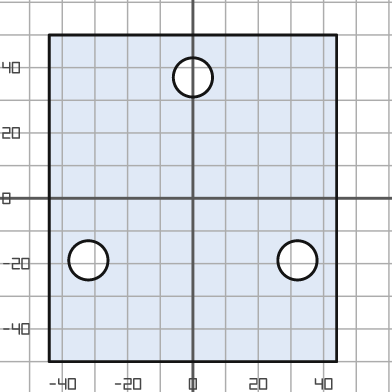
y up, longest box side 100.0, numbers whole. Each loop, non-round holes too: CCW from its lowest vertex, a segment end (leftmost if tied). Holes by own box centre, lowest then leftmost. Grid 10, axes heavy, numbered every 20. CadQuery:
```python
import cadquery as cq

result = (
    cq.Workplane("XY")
    .moveTo(-44.0, -50.0)
    .lineTo(44.0, -50.0)
    .lineTo(44.0, 50.0)
    .lineTo(-44.0, 50.0)
    .close()
    .moveTo(-32.0, -19.0)
    .circle(6.0)
    .moveTo(32.0, -19.0)
    .circle(6.0)
    .moveTo(0.0, 37.0)
    .circle(6.0)
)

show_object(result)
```